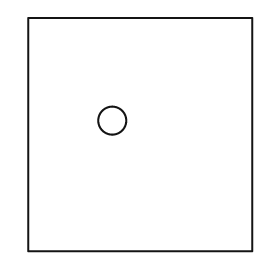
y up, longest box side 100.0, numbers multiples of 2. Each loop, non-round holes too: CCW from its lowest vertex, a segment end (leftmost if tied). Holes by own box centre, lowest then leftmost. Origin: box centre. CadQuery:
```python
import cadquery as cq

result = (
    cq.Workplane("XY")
    .moveTo(-48.0, -50.0)
    .lineTo(48.0, -50.0)
    .lineTo(48.0, 50.0)
    .lineTo(-48.0, 50.0)
    .close()
    .moveTo(-12.0, 6.0)
    .circle(6.0)
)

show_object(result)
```